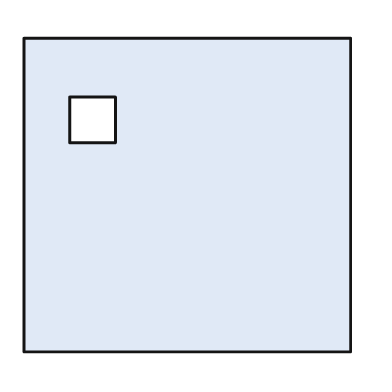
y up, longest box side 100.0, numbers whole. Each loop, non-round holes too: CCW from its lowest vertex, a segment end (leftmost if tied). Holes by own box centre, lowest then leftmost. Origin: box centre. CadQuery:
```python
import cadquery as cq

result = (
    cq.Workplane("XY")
    .moveTo(-50.0, -48.0)
    .lineTo(50.0, -48.0)
    .lineTo(50.0, 48.0)
    .lineTo(-50.0, 48.0)
    .close()
    .moveTo(-36.0, 16.0)
    .lineTo(-22.0, 16.0)
    .lineTo(-22.0, 30.0)
    .lineTo(-36.0, 30.0)
    .close()
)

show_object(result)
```